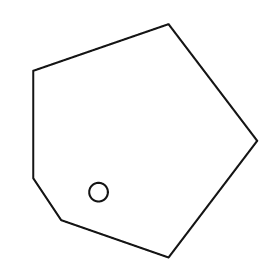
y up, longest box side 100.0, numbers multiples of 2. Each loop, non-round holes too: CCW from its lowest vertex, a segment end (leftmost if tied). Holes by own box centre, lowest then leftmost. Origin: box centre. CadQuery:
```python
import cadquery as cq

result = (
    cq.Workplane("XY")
    .moveTo(10.0, -50.0)
    .lineTo(48.0, 0.0)
    .lineTo(10.0, 50.0)
    .lineTo(-48.0, 30.0)
    .lineTo(-48.0, -16.0)
    .lineTo(-36.0, -34.0)
    .close()
    .moveTo(-20.0, -22.0)
    .circle(4.0)
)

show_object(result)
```